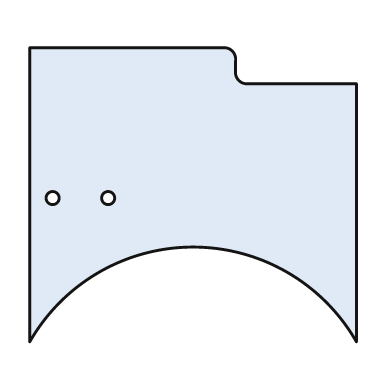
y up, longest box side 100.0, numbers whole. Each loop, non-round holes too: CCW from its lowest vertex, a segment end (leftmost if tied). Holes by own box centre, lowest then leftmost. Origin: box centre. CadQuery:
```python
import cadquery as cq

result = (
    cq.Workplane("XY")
    .moveTo(-50.0, -45.0)
    .threePointArc((0.0, -16.0), (50.0, -45.0))
    .lineTo(50.0, 34.0)
    .lineTo(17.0, 34.0)
    .threePointArc((14.0, 35.0), (13.0, 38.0))
    .lineTo(13.0, 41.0)
    .threePointArc((12.0, 44.0), (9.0, 45.0))
    .lineTo(-50.0, 45.0)
    .close()
    .moveTo(-43.0, -1.0)
    .circle(2.0)
    .moveTo(-26.0, -1.0)
    .circle(2.0)
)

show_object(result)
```